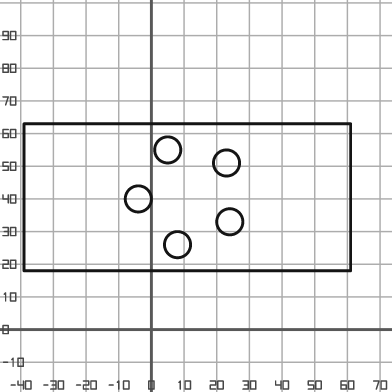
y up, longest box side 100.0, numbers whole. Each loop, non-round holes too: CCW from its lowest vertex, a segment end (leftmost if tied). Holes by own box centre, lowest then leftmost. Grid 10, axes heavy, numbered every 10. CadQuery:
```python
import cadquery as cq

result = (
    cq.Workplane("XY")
    .moveTo(-39.0, 18.0)
    .lineTo(61.0, 18.0)
    .lineTo(61.0, 63.0)
    .lineTo(-39.0, 63.0)
    .close()
    .moveTo(8.0, 26.0)
    .circle(4.0)
    .moveTo(24.0, 33.0)
    .circle(4.0)
    .moveTo(-4.0, 40.0)
    .circle(4.0)
    .moveTo(23.0, 51.0)
    .circle(4.0)
    .moveTo(5.0, 55.0)
    .circle(4.0)
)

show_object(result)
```